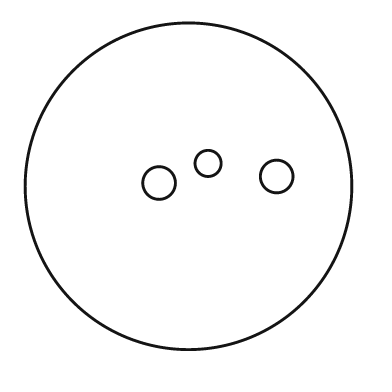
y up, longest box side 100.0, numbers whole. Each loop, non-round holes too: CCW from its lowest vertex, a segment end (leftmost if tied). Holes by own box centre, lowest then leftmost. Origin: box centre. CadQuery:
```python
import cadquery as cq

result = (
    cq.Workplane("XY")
    .moveTo(0.0, 0.0)
    .circle(50.0)
    .moveTo(-9.0, 1.0)
    .circle(5.0)
    .moveTo(27.0, 3.0)
    .circle(5.0)
    .moveTo(6.0, 7.0)
    .circle(4.0)
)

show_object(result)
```